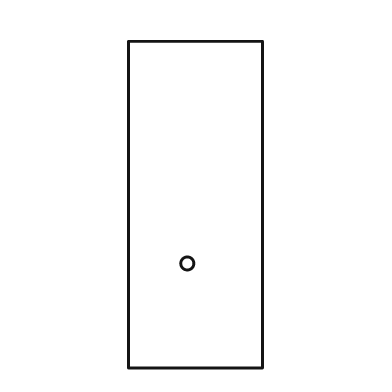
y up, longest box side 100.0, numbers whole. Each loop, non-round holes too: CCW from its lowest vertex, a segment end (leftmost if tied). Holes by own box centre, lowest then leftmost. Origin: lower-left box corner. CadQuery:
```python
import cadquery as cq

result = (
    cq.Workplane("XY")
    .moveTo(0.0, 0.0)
    .lineTo(41.0, 0.0)
    .lineTo(41.0, 100.0)
    .lineTo(0.0, 100.0)
    .close()
    .moveTo(18.0, 32.0)
    .circle(2.0)
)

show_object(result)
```